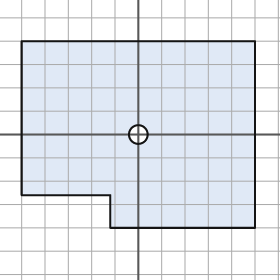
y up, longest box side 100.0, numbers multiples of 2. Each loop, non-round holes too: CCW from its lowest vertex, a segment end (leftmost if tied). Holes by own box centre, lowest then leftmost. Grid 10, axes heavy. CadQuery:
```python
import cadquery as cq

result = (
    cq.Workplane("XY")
    .moveTo(-12.0, -40.0)
    .lineTo(50.0, -40.0)
    .lineTo(50.0, 40.0)
    .lineTo(-50.0, 40.0)
    .lineTo(-50.0, -26.0)
    .lineTo(-12.0, -26.0)
    .close()
    .moveTo(0.0, 0.0)
    .circle(4.0)
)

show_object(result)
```